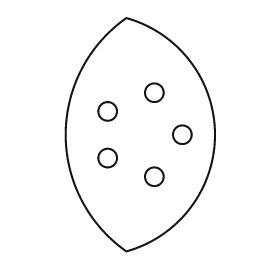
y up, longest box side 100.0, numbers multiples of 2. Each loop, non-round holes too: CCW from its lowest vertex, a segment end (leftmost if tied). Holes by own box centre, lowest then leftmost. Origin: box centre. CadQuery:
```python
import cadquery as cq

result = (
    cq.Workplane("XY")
    .moveTo(-6.0, -50.0)
    .threePointArc((32.0, 0.0), (-6.0, 50.0))
    .threePointArc((-32.0, 0.0), (-6.0, -50.0))
    .close()
    .moveTo(6.0, -18.0)
    .circle(4.0)
    .moveTo(-14.0, -10.0)
    .circle(4.0)
    .moveTo(18.0, 0.0)
    .circle(4.0)
    .moveTo(-14.0, 10.0)
    .circle(4.0)
    .moveTo(6.0, 18.0)
    .circle(4.0)
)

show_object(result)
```